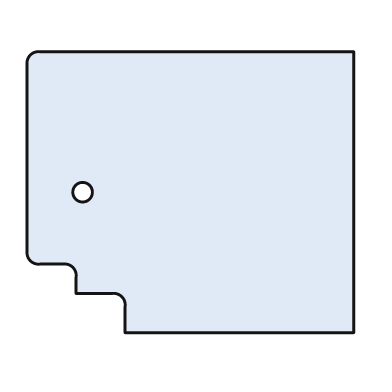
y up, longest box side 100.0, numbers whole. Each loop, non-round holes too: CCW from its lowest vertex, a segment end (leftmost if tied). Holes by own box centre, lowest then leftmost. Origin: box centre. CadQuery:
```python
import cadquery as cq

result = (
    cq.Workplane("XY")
    .moveTo(-20.0, -43.0)
    .lineTo(50.0, -43.0)
    .lineTo(50.0, 43.0)
    .lineTo(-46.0, 43.0)
    .threePointArc((-49.0, 42.0), (-50.0, 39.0))
    .lineTo(-50.0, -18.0)
    .threePointArc((-49.0, -21.0), (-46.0, -22.0))
    .lineTo(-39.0, -22.0)
    .threePointArc((-36.0, -23.0), (-35.0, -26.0))
    .lineTo(-35.0, -31.0)
    .lineTo(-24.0, -31.0)
    .threePointArc((-21.0, -32.0), (-20.0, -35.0))
    .close()
    .moveTo(-33.0, 0.0)
    .circle(3.0)
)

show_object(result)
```